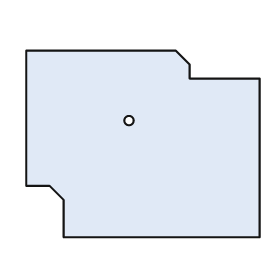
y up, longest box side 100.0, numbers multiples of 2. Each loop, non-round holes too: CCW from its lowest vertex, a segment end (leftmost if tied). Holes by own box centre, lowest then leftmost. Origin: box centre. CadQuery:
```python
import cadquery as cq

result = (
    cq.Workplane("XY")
    .moveTo(-34.0, -40.0)
    .lineTo(50.0, -40.0)
    .lineTo(50.0, 28.0)
    .lineTo(20.0, 28.0)
    .lineTo(20.0, 34.0)
    .lineTo(14.0, 40.0)
    .lineTo(-50.0, 40.0)
    .lineTo(-50.0, -18.0)
    .lineTo(-40.0, -18.0)
    .lineTo(-34.0, -24.0)
    .close()
    .moveTo(-6.0, 10.0)
    .circle(2.0)
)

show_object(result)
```